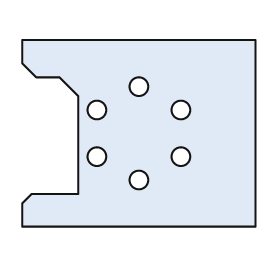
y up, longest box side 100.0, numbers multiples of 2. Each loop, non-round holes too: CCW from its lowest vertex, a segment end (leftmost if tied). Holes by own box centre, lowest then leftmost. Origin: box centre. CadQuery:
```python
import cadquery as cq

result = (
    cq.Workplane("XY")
    .moveTo(-50.0, -40.0)
    .lineTo(50.0, -40.0)
    .lineTo(50.0, 40.0)
    .lineTo(-50.0, 40.0)
    .lineTo(-50.0, 30.0)
    .lineTo(-44.0, 24.0)
    .lineTo(-34.0, 24.0)
    .lineTo(-26.0, 16.0)
    .lineTo(-26.0, -26.0)
    .lineTo(-46.0, -26.0)
    .lineTo(-50.0, -30.0)
    .close()
    .moveTo(0.0, -20.0)
    .circle(4.0)
    .moveTo(-18.0, -10.0)
    .circle(4.0)
    .moveTo(18.0, -10.0)
    .circle(4.0)
    .moveTo(-18.0, 10.0)
    .circle(4.0)
    .moveTo(18.0, 10.0)
    .circle(4.0)
    .moveTo(0.0, 20.0)
    .circle(4.0)
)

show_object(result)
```